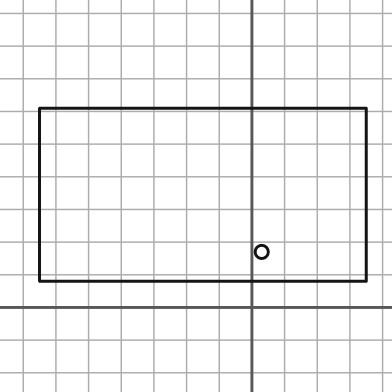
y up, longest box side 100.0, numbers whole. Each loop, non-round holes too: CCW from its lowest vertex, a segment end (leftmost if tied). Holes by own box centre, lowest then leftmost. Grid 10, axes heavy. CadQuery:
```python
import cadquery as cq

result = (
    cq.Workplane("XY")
    .moveTo(-65.0, 8.0)
    .lineTo(35.0, 8.0)
    .lineTo(35.0, 61.0)
    .lineTo(-65.0, 61.0)
    .close()
    .moveTo(3.0, 17.0)
    .circle(2.0)
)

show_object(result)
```